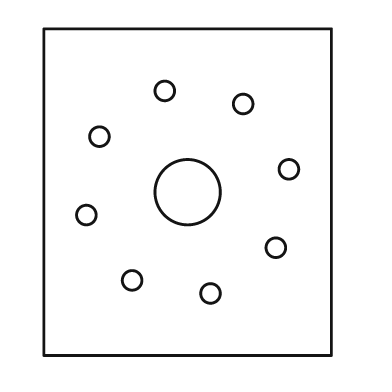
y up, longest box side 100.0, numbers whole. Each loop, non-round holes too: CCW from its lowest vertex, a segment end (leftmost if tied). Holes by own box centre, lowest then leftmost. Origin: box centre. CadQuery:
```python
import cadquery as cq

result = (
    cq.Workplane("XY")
    .moveTo(-44.0, -50.0)
    .lineTo(44.0, -50.0)
    .lineTo(44.0, 50.0)
    .lineTo(-44.0, 50.0)
    .close()
    .moveTo(7.0, -31.0)
    .circle(3.0)
    .moveTo(-17.0, -27.0)
    .circle(3.0)
    .moveTo(27.0, -17.0)
    .circle(3.0)
    .moveTo(-31.0, -7.0)
    .circle(3.0)
    .moveTo(0.0, 0.0)
    .circle(10.0)
    .moveTo(31.0, 7.0)
    .circle(3.0)
    .moveTo(-27.0, 17.0)
    .circle(3.0)
    .moveTo(17.0, 27.0)
    .circle(3.0)
    .moveTo(-7.0, 31.0)
    .circle(3.0)
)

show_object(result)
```